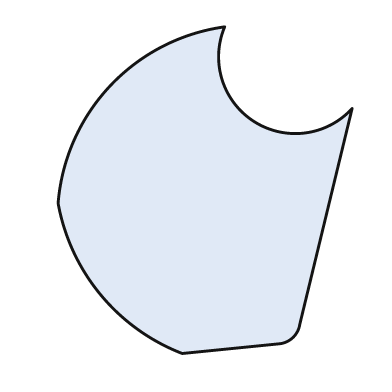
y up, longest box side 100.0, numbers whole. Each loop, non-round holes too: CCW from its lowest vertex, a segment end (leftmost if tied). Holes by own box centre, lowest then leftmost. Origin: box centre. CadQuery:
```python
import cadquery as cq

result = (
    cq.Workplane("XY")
    .moveTo(-7.0, -50.0)
    .lineTo(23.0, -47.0)
    .threePointArc((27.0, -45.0), (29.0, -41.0))
    .lineTo(45.0, 25.0)
    .threePointArc((15.0, 21.0), (6.0, 50.0))
    .threePointArc((-29.0, 32.0), (-45.0, -4.0))
    .threePointArc((-32.0, -32.0), (-7.0, -50.0))
    .close()
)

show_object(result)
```